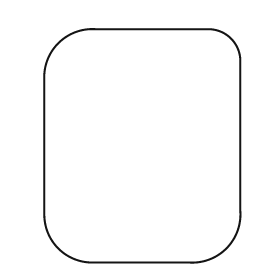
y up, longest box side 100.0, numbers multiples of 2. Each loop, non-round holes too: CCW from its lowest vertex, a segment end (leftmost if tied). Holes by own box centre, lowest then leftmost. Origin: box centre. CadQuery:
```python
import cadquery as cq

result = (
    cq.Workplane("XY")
    .moveTo(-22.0, -50.0)
    .lineTo(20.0, -50.0)
    .threePointArc((36.0, -44.0), (42.0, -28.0))
    .lineTo(42.0, 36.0)
    .threePointArc((38.0, 46.0), (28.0, 50.0))
    .lineTo(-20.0, 50.0)
    .threePointArc((-36.0, 44.0), (-42.0, 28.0))
    .lineTo(-42.0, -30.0)
    .threePointArc((-36.0, -44.0), (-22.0, -50.0))
    .close()
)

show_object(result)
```